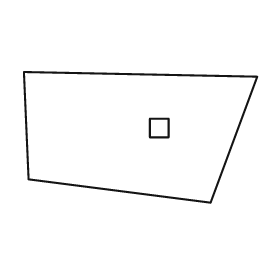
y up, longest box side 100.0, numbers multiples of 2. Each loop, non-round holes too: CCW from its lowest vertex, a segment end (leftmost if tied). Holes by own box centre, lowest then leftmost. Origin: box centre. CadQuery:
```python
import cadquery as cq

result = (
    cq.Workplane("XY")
    .moveTo(30.0, -28.0)
    .lineTo(50.0, 26.0)
    .lineTo(-50.0, 28.0)
    .lineTo(-48.0, -18.0)
    .close()
    .moveTo(4.0, 0.0)
    .lineTo(12.0, 0.0)
    .lineTo(12.0, 8.0)
    .lineTo(4.0, 8.0)
    .close()
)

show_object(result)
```